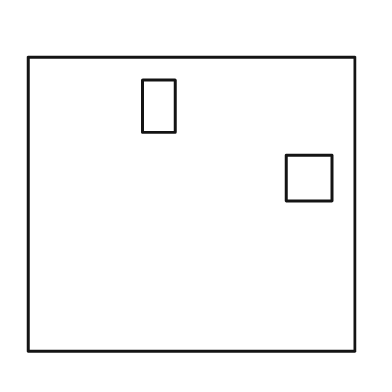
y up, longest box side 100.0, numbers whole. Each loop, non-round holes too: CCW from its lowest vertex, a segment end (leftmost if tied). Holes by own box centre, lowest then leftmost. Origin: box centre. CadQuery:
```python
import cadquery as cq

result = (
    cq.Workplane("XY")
    .moveTo(-50.0, -45.0)
    .lineTo(50.0, -45.0)
    .lineTo(50.0, 45.0)
    .lineTo(-50.0, 45.0)
    .close()
    .moveTo(29.0, 1.0)
    .lineTo(43.0, 1.0)
    .lineTo(43.0, 15.0)
    .lineTo(29.0, 15.0)
    .close()
    .moveTo(-15.0, 22.0)
    .lineTo(-5.0, 22.0)
    .lineTo(-5.0, 38.0)
    .lineTo(-15.0, 38.0)
    .close()
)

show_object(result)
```